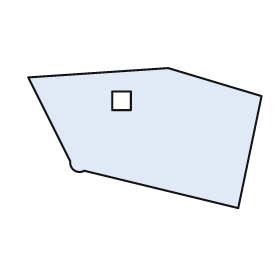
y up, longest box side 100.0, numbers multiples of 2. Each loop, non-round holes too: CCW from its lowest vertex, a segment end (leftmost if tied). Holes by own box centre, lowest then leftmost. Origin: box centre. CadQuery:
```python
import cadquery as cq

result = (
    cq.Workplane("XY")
    .moveTo(40.0, -30.0)
    .lineTo(50.0, 18.0)
    .lineTo(10.0, 30.0)
    .lineTo(-50.0, 26.0)
    .lineTo(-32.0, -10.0)
    .threePointArc((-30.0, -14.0), (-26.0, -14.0))
    .close()
    .moveTo(-14.0, 12.0)
    .lineTo(-6.0, 12.0)
    .lineTo(-6.0, 20.0)
    .lineTo(-14.0, 20.0)
    .close()
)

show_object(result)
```